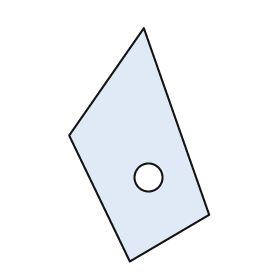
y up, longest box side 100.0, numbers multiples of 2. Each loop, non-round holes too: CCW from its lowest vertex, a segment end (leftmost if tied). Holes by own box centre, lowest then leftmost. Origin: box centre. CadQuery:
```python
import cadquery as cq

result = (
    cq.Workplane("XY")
    .moveTo(-4.0, -50.0)
    .lineTo(30.0, -30.0)
    .lineTo(2.0, 50.0)
    .lineTo(-30.0, 4.0)
    .close()
    .moveTo(4.0, -14.0)
    .circle(6.0)
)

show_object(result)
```